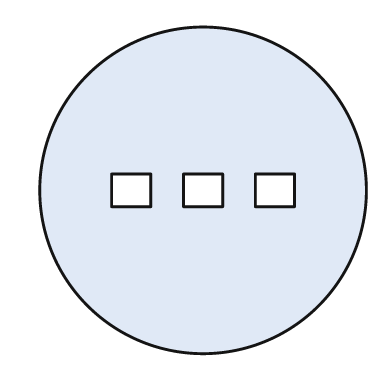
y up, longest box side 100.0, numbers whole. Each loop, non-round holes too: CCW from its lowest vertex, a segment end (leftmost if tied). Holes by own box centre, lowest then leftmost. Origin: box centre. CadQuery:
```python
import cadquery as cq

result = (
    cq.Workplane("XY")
    .moveTo(0.0, 0.0)
    .circle(50.0)
    .moveTo(-28.0, -5.0)
    .lineTo(-16.0, -5.0)
    .lineTo(-16.0, 5.0)
    .lineTo(-28.0, 5.0)
    .close()
    .moveTo(-6.0, -5.0)
    .lineTo(6.0, -5.0)
    .lineTo(6.0, 5.0)
    .lineTo(-6.0, 5.0)
    .close()
    .moveTo(16.0, -5.0)
    .lineTo(28.0, -5.0)
    .lineTo(28.0, 5.0)
    .lineTo(16.0, 5.0)
    .close()
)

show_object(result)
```